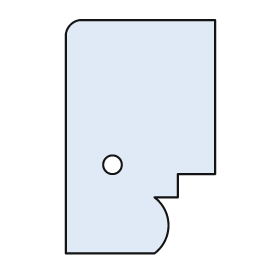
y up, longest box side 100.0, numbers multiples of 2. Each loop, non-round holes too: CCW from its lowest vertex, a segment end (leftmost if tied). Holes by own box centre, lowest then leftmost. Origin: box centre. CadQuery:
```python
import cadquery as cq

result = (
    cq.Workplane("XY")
    .moveTo(-32.0, -50.0)
    .lineTo(6.0, -50.0)
    .threePointArc((12.0, -38.0), (6.0, -26.0))
    .lineTo(16.0, -26.0)
    .lineTo(16.0, -16.0)
    .lineTo(32.0, -16.0)
    .lineTo(32.0, 50.0)
    .lineTo(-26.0, 50.0)
    .threePointArc((-30.0, 48.0), (-32.0, 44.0))
    .close()
    .moveTo(-12.0, -12.0)
    .circle(4.0)
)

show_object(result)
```